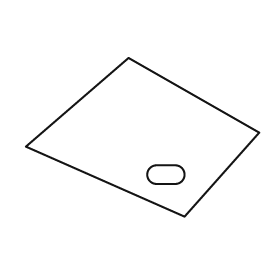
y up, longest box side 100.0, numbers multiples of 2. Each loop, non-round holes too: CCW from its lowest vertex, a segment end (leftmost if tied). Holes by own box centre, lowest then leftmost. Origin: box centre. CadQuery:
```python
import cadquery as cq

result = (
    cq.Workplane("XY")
    .moveTo(18.0, -34.0)
    .lineTo(50.0, 2.0)
    .lineTo(-6.0, 34.0)
    .lineTo(-50.0, -4.0)
    .close()
    .moveTo(6.0, -20.0)
    .lineTo(14.0, -20.0)
    .threePointArc((18.0, -16.0), (14.0, -12.0))
    .lineTo(6.0, -12.0)
    .threePointArc((2.0, -16.0), (6.0, -20.0))
    .close()
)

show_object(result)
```